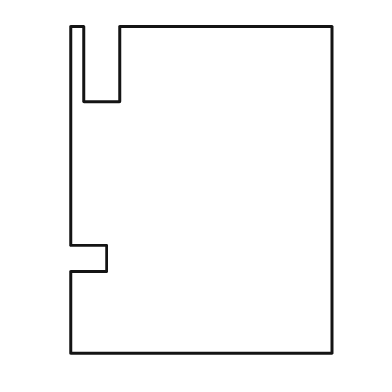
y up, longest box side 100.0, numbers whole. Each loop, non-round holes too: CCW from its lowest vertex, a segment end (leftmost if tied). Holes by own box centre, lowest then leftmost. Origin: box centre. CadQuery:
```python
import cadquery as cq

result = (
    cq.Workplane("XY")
    .moveTo(-40.0, -50.0)
    .lineTo(40.0, -50.0)
    .lineTo(40.0, 50.0)
    .lineTo(-25.0, 50.0)
    .lineTo(-25.0, 27.0)
    .lineTo(-36.0, 27.0)
    .lineTo(-36.0, 50.0)
    .lineTo(-40.0, 50.0)
    .lineTo(-40.0, -17.0)
    .lineTo(-29.0, -17.0)
    .lineTo(-29.0, -25.0)
    .lineTo(-40.0, -25.0)
    .close()
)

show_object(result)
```